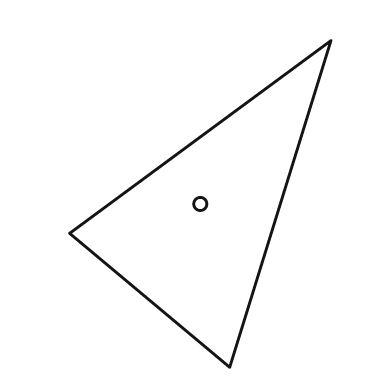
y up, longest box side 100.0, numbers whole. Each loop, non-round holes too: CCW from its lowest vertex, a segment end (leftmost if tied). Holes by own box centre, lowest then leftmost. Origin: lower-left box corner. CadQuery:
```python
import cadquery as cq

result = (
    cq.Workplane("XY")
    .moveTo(49.0, 0.0)
    .lineTo(80.0, 100.0)
    .lineTo(0.0, 41.0)
    .close()
    .moveTo(40.0, 50.0)
    .circle(2.0)
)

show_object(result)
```